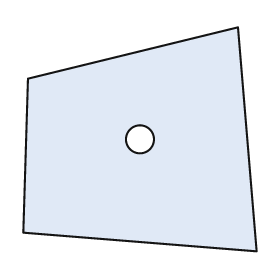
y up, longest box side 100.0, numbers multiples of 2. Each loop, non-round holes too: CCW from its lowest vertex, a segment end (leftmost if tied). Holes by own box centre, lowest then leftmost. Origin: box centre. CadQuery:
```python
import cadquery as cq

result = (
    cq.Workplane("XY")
    .moveTo(50.0, -48.0)
    .lineTo(42.0, 48.0)
    .lineTo(-48.0, 26.0)
    .lineTo(-50.0, -40.0)
    .close()
    .moveTo(0.0, 0.0)
    .circle(6.0)
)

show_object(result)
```